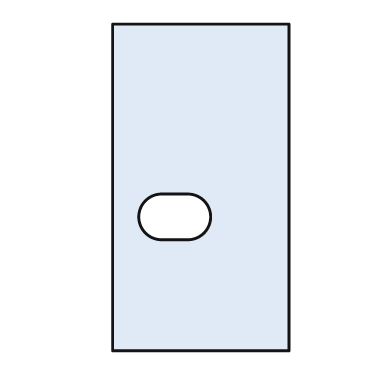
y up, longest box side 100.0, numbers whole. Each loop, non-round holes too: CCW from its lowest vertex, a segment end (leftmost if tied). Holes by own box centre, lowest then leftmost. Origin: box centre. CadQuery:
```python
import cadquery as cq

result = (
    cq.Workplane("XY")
    .moveTo(-27.0, -50.0)
    .lineTo(27.0, -50.0)
    .lineTo(27.0, 50.0)
    .lineTo(-27.0, 50.0)
    .close()
    .moveTo(-12.0, -16.0)
    .lineTo(-4.0, -16.0)
    .threePointArc((3.0, -9.0), (-4.0, -2.0))
    .lineTo(-12.0, -2.0)
    .threePointArc((-19.0, -9.0), (-12.0, -16.0))
    .close()
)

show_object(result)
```